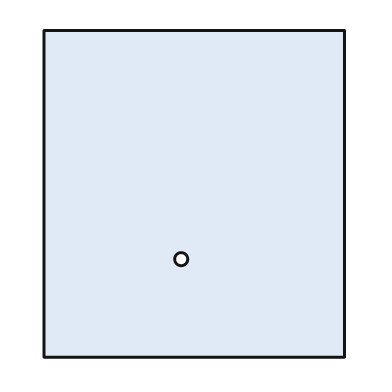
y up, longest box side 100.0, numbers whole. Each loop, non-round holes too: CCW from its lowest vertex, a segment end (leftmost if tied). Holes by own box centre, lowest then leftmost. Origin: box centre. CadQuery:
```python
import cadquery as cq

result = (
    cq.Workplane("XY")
    .moveTo(-46.0, -50.0)
    .lineTo(46.0, -50.0)
    .lineTo(46.0, 50.0)
    .lineTo(-46.0, 50.0)
    .close()
    .moveTo(-4.0, -20.0)
    .circle(2.0)
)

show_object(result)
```